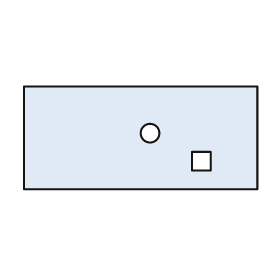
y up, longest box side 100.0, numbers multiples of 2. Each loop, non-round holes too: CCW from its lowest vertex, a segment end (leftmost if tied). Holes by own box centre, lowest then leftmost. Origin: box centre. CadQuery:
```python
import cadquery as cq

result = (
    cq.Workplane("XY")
    .moveTo(-50.0, -22.0)
    .lineTo(50.0, -22.0)
    .lineTo(50.0, 22.0)
    .lineTo(-50.0, 22.0)
    .close()
    .moveTo(22.0, -14.0)
    .lineTo(30.0, -14.0)
    .lineTo(30.0, -6.0)
    .lineTo(22.0, -6.0)
    .close()
    .moveTo(4.0, 2.0)
    .circle(4.0)
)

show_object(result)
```